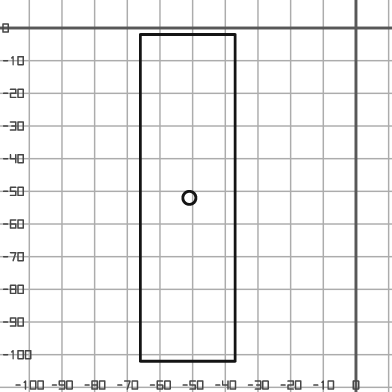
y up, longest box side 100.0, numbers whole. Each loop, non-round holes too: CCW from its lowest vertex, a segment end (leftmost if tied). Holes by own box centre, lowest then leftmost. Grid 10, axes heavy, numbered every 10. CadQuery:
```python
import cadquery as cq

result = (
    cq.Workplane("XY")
    .moveTo(-66.0, -102.0)
    .lineTo(-37.0, -102.0)
    .lineTo(-37.0, -2.0)
    .lineTo(-66.0, -2.0)
    .close()
    .moveTo(-51.0, -52.0)
    .circle(2.0)
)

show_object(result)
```